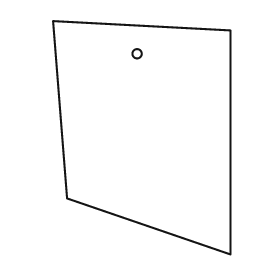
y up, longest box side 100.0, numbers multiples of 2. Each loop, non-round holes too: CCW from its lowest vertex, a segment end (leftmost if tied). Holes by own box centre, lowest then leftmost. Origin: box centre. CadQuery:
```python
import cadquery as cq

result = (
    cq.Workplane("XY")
    .moveTo(38.0, -50.0)
    .lineTo(38.0, 46.0)
    .lineTo(-38.0, 50.0)
    .lineTo(-32.0, -26.0)
    .close()
    .moveTo(-2.0, 36.0)
    .circle(2.0)
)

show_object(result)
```